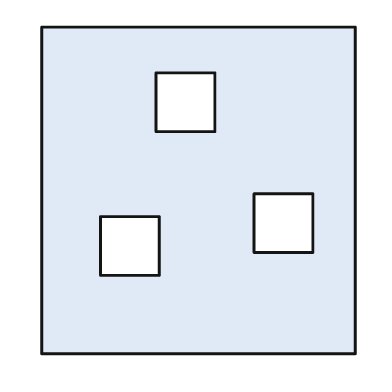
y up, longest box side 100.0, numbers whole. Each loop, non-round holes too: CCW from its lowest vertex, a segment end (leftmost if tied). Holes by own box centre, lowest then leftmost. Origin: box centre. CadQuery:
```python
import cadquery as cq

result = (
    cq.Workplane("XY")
    .moveTo(-48.0, -50.0)
    .lineTo(48.0, -50.0)
    .lineTo(48.0, 50.0)
    .lineTo(-48.0, 50.0)
    .close()
    .moveTo(-30.0, -26.0)
    .lineTo(-12.0, -26.0)
    .lineTo(-12.0, -8.0)
    .lineTo(-30.0, -8.0)
    .close()
    .moveTo(17.0, -19.0)
    .lineTo(35.0, -19.0)
    .lineTo(35.0, -1.0)
    .lineTo(17.0, -1.0)
    .close()
    .moveTo(-13.0, 18.0)
    .lineTo(5.0, 18.0)
    .lineTo(5.0, 36.0)
    .lineTo(-13.0, 36.0)
    .close()
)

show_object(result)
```